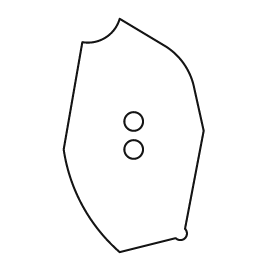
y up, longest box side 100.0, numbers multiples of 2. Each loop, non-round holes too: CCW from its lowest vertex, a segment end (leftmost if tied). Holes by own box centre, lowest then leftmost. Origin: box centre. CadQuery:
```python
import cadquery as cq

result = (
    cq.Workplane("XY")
    .moveTo(-6.0, -50.0)
    .lineTo(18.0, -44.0)
    .threePointArc((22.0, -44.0), (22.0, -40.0))
    .lineTo(30.0, 2.0)
    .lineTo(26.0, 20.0)
    .threePointArc((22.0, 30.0), (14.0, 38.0))
    .lineTo(-6.0, 50.0)
    .threePointArc((-12.0, 42.0), (-22.0, 40.0))
    .lineTo(-30.0, -6.0)
    .threePointArc((-22.0, -30.0), (-6.0, -50.0))
    .close()
    .moveTo(0.0, -6.0)
    .circle(4.0)
    .moveTo(0.0, 6.0)
    .circle(4.0)
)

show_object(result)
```